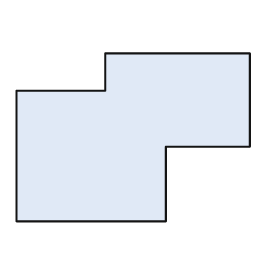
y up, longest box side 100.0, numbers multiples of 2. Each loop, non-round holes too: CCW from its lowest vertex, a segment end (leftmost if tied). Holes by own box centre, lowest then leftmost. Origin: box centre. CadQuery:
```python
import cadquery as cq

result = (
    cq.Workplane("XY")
    .moveTo(-50.0, -36.0)
    .lineTo(14.0, -36.0)
    .lineTo(14.0, -4.0)
    .lineTo(50.0, -4.0)
    .lineTo(50.0, 36.0)
    .lineTo(-12.0, 36.0)
    .lineTo(-12.0, 20.0)
    .lineTo(-50.0, 20.0)
    .close()
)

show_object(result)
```